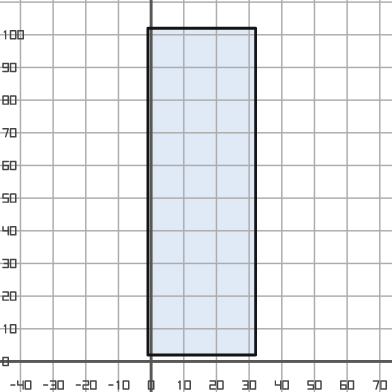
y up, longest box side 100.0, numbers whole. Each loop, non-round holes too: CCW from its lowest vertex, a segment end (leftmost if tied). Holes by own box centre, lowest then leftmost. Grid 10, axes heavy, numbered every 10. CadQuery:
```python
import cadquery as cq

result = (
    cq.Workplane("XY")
    .moveTo(-1.0, 2.0)
    .lineTo(32.0, 2.0)
    .lineTo(32.0, 102.0)
    .lineTo(-1.0, 102.0)
    .close()
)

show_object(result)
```